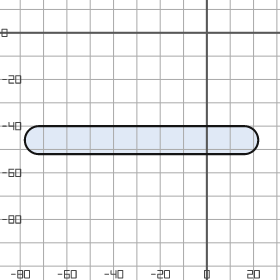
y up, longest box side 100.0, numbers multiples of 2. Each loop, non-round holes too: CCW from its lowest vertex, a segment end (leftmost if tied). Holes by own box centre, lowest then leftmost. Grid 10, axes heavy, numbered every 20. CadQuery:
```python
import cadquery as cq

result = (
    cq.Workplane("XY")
    .moveTo(-72.0, -52.0)
    .lineTo(16.0, -52.0)
    .threePointArc((22.0, -46.0), (16.0, -40.0))
    .lineTo(-72.0, -40.0)
    .threePointArc((-78.0, -46.0), (-72.0, -52.0))
    .close()
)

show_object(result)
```